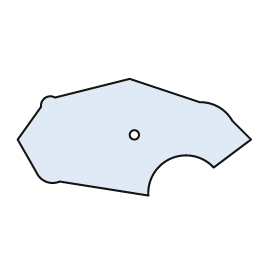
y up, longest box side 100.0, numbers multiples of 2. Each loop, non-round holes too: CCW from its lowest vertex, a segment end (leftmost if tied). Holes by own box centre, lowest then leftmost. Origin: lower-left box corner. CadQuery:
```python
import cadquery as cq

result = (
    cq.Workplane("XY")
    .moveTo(56.0, 0.0)
    .threePointArc((66.0, 16.0), (84.0, 12.0))
    .lineTo(100.0, 24.0)
    .lineTo(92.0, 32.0)
    .threePointArc((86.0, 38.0), (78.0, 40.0))
    .lineTo(48.0, 50.0)
    .lineTo(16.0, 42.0)
    .threePointArc((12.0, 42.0), (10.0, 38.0))
    .lineTo(0.0, 24.0)
    .lineTo(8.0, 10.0)
    .threePointArc((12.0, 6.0), (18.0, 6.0))
    .close()
    .moveTo(50.0, 26.0)
    .circle(2.0)
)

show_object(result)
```